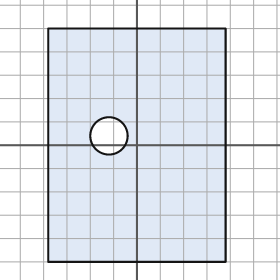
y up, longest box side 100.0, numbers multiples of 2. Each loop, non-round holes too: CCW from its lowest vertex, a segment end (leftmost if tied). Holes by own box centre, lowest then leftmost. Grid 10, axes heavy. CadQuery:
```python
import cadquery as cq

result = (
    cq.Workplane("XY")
    .moveTo(-38.0, -50.0)
    .lineTo(38.0, -50.0)
    .lineTo(38.0, 50.0)
    .lineTo(-38.0, 50.0)
    .close()
    .moveTo(-12.0, 4.0)
    .circle(8.0)
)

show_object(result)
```